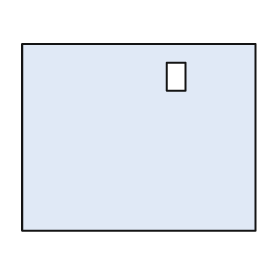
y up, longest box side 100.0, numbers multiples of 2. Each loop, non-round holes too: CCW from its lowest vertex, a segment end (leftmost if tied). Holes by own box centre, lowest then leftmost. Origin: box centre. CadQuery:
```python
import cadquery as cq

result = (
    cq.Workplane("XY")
    .moveTo(-50.0, -40.0)
    .lineTo(50.0, -40.0)
    .lineTo(50.0, 40.0)
    .lineTo(-50.0, 40.0)
    .close()
    .moveTo(12.0, 20.0)
    .lineTo(20.0, 20.0)
    .lineTo(20.0, 32.0)
    .lineTo(12.0, 32.0)
    .close()
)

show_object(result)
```